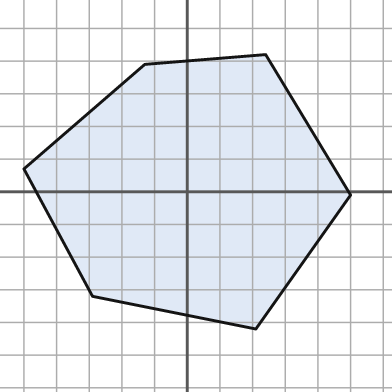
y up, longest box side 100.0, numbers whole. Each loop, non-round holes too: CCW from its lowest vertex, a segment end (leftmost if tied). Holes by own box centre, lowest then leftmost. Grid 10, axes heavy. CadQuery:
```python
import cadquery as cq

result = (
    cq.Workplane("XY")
    .moveTo(21.0, -42.0)
    .lineTo(50.0, -1.0)
    .lineTo(24.0, 42.0)
    .lineTo(-13.0, 39.0)
    .lineTo(-50.0, 7.0)
    .lineTo(-29.0, -32.0)
    .close()
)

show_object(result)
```